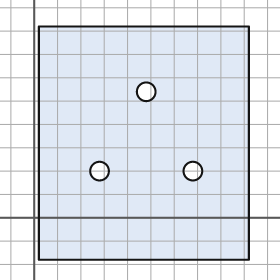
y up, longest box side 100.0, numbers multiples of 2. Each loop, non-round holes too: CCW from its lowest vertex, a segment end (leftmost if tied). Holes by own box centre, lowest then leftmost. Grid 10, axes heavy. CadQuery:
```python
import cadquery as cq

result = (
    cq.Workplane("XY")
    .moveTo(2.0, -18.0)
    .lineTo(92.0, -18.0)
    .lineTo(92.0, 82.0)
    .lineTo(2.0, 82.0)
    .close()
    .moveTo(28.0, 20.0)
    .circle(4.0)
    .moveTo(68.0, 20.0)
    .circle(4.0)
    .moveTo(48.0, 54.0)
    .circle(4.0)
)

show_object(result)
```